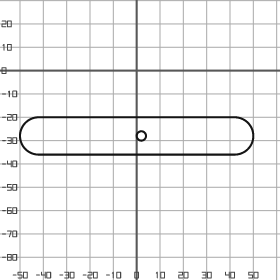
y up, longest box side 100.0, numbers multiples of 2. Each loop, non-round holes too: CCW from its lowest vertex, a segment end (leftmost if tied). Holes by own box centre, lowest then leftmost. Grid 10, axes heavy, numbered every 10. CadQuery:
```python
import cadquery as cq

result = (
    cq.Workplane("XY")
    .moveTo(-42.0, -36.0)
    .lineTo(42.0, -36.0)
    .threePointArc((50.0, -28.0), (42.0, -20.0))
    .lineTo(-42.0, -20.0)
    .threePointArc((-50.0, -28.0), (-42.0, -36.0))
    .close()
    .moveTo(2.0, -28.0)
    .circle(2.0)
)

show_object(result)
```